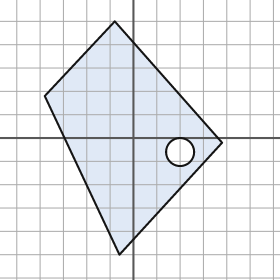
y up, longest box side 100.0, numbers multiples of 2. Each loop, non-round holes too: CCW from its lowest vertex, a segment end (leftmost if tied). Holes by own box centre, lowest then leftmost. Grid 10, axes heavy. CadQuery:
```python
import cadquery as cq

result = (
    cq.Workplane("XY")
    .moveTo(-6.0, -50.0)
    .lineTo(38.0, -2.0)
    .lineTo(-8.0, 50.0)
    .lineTo(-38.0, 18.0)
    .close()
    .moveTo(20.0, -6.0)
    .circle(6.0)
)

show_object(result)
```